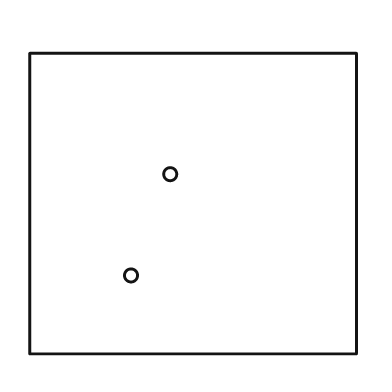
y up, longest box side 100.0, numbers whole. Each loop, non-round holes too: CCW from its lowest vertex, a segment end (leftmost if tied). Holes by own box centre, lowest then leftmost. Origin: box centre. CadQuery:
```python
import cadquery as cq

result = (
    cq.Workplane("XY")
    .moveTo(-50.0, -46.0)
    .lineTo(50.0, -46.0)
    .lineTo(50.0, 46.0)
    .lineTo(-50.0, 46.0)
    .close()
    .moveTo(-19.0, -22.0)
    .circle(2.0)
    .moveTo(-7.0, 9.0)
    .circle(2.0)
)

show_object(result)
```